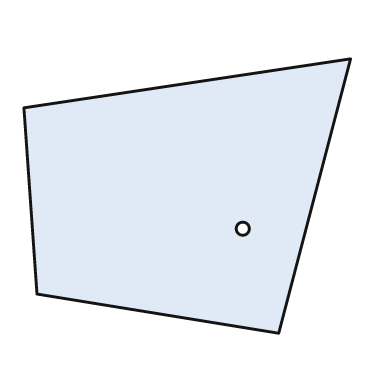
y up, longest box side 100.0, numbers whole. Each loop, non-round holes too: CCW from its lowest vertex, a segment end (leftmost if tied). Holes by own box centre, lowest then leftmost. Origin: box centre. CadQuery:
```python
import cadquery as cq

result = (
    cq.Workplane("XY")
    .moveTo(28.0, -42.0)
    .lineTo(50.0, 42.0)
    .lineTo(-50.0, 27.0)
    .lineTo(-46.0, -30.0)
    .close()
    .moveTo(17.0, -10.0)
    .circle(2.0)
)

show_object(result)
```